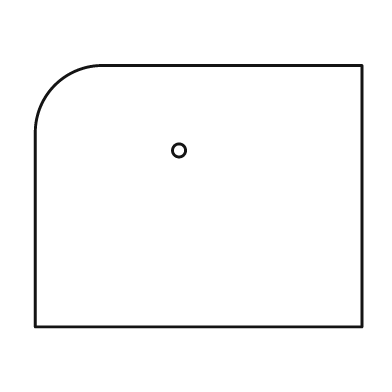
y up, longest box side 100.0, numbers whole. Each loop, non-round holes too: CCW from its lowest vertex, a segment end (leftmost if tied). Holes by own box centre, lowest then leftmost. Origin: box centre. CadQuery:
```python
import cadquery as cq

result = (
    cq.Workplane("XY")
    .moveTo(-50.0, -40.0)
    .lineTo(50.0, -40.0)
    .lineTo(50.0, 40.0)
    .lineTo(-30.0, 40.0)
    .threePointArc((-44.0, 34.0), (-50.0, 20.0))
    .close()
    .moveTo(-6.0, 14.0)
    .circle(2.0)
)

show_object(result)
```